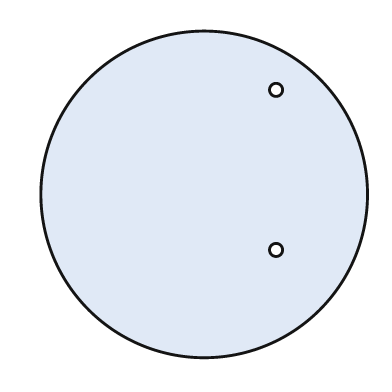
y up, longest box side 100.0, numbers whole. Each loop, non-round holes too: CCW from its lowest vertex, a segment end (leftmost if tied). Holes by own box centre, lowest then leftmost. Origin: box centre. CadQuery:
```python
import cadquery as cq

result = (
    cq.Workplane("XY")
    .moveTo(0.0, 0.0)
    .circle(50.0)
    .moveTo(22.0, -17.0)
    .circle(2.0)
    .moveTo(22.0, 32.0)
    .circle(2.0)
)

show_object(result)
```